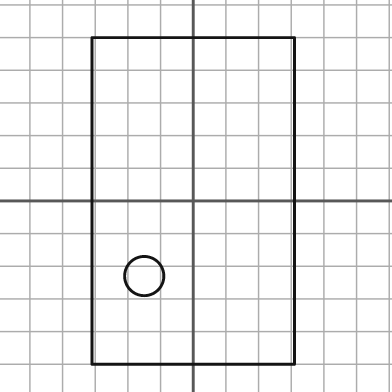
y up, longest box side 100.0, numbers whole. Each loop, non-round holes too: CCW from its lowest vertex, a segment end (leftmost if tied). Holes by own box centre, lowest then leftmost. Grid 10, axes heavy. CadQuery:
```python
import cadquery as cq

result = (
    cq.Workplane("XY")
    .moveTo(-31.0, -50.0)
    .lineTo(31.0, -50.0)
    .lineTo(31.0, 50.0)
    .lineTo(-31.0, 50.0)
    .close()
    .moveTo(-15.0, -23.0)
    .circle(6.0)
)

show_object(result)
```